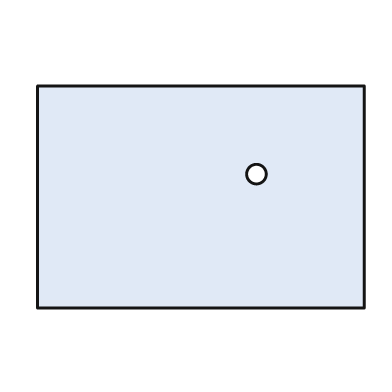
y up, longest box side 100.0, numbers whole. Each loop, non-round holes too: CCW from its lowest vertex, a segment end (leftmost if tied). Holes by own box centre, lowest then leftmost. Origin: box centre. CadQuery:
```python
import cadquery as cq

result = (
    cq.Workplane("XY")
    .moveTo(-50.0, -34.0)
    .lineTo(50.0, -34.0)
    .lineTo(50.0, 34.0)
    .lineTo(-50.0, 34.0)
    .close()
    .moveTo(17.0, 7.0)
    .circle(3.0)
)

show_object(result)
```